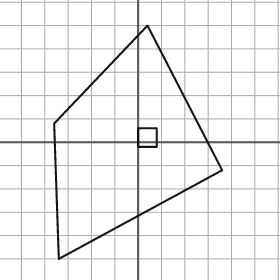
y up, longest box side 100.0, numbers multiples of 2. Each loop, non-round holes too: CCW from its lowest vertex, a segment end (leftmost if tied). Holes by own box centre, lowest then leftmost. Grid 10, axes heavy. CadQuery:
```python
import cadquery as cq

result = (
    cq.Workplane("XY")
    .moveTo(-34.0, -50.0)
    .lineTo(36.0, -12.0)
    .lineTo(4.0, 50.0)
    .lineTo(-36.0, 8.0)
    .close()
    .moveTo(0.0, -2.0)
    .lineTo(8.0, -2.0)
    .lineTo(8.0, 6.0)
    .lineTo(0.0, 6.0)
    .close()
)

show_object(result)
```